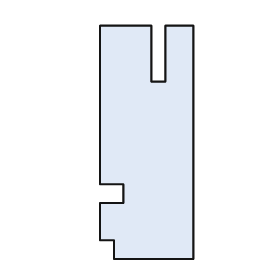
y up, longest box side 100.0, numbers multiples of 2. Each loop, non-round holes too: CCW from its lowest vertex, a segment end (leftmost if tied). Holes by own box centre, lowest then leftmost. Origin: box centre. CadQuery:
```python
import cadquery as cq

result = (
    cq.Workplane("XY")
    .moveTo(-14.0, -50.0)
    .lineTo(20.0, -50.0)
    .lineTo(20.0, 50.0)
    .lineTo(8.0, 50.0)
    .lineTo(8.0, 26.0)
    .lineTo(2.0, 26.0)
    .lineTo(2.0, 50.0)
    .lineTo(-20.0, 50.0)
    .lineTo(-20.0, -18.0)
    .lineTo(-10.0, -18.0)
    .lineTo(-10.0, -26.0)
    .lineTo(-20.0, -26.0)
    .lineTo(-20.0, -42.0)
    .lineTo(-14.0, -42.0)
    .close()
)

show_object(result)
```